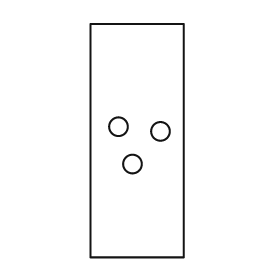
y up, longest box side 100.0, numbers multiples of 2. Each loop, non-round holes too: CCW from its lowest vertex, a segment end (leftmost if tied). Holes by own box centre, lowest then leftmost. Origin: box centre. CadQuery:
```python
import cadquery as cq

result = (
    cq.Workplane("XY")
    .moveTo(-20.0, -50.0)
    .lineTo(20.0, -50.0)
    .lineTo(20.0, 50.0)
    .lineTo(-20.0, 50.0)
    .close()
    .moveTo(-2.0, -10.0)
    .circle(4.0)
    .moveTo(10.0, 4.0)
    .circle(4.0)
    .moveTo(-8.0, 6.0)
    .circle(4.0)
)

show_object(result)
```